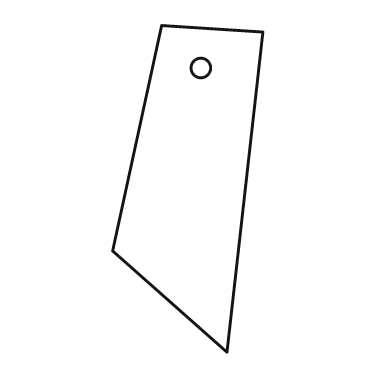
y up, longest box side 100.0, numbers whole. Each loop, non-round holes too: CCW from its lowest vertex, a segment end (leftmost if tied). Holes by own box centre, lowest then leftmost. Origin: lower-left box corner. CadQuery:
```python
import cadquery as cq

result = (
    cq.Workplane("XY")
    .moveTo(35.0, 0.0)
    .lineTo(46.0, 98.0)
    .lineTo(15.0, 100.0)
    .lineTo(0.0, 31.0)
    .close()
    .moveTo(27.0, 87.0)
    .circle(3.0)
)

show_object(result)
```